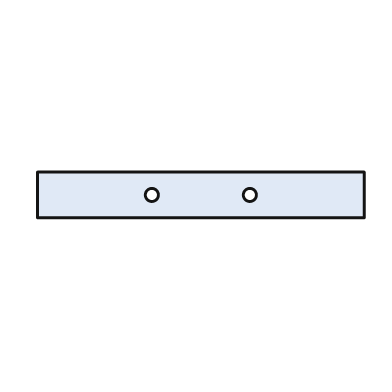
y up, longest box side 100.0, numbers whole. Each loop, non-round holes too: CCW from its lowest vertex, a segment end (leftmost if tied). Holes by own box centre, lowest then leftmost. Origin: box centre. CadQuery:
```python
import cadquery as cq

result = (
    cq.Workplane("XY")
    .moveTo(-50.0, -7.0)
    .lineTo(50.0, -7.0)
    .lineTo(50.0, 7.0)
    .lineTo(-50.0, 7.0)
    .close()
    .moveTo(-15.0, 0.0)
    .circle(2.0)
    .moveTo(15.0, 0.0)
    .circle(2.0)
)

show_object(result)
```